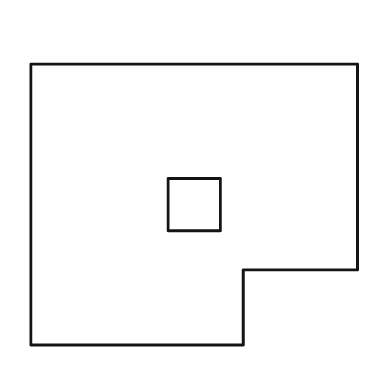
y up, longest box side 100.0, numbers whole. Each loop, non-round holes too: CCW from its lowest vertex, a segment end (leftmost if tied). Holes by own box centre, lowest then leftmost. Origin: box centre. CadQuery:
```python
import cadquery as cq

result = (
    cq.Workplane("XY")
    .moveTo(-50.0, -43.0)
    .lineTo(15.0, -43.0)
    .lineTo(15.0, -20.0)
    .lineTo(50.0, -20.0)
    .lineTo(50.0, 43.0)
    .lineTo(-50.0, 43.0)
    .close()
    .moveTo(-8.0, -8.0)
    .lineTo(8.0, -8.0)
    .lineTo(8.0, 8.0)
    .lineTo(-8.0, 8.0)
    .close()
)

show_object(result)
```